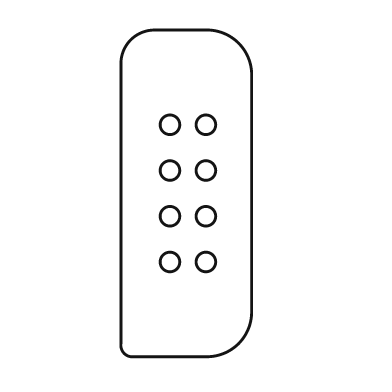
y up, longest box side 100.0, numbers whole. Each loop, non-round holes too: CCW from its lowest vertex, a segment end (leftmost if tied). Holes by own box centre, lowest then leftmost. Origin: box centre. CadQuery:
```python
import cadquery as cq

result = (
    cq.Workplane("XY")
    .moveTo(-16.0, -50.0)
    .lineTo(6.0, -50.0)
    .threePointArc((16.0, -46.0), (20.0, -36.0))
    .lineTo(20.0, 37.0)
    .threePointArc((16.0, 46.0), (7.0, 50.0))
    .lineTo(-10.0, 50.0)
    .threePointArc((-17.0, 47.0), (-20.0, 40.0))
    .lineTo(-20.0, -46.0)
    .threePointArc((-19.0, -49.0), (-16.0, -50.0))
    .close()
    .moveTo(-5.0, -21.0)
    .circle(3.0)
    .moveTo(6.0, -21.0)
    .circle(3.0)
    .moveTo(-5.0, -7.0)
    .circle(3.0)
    .moveTo(6.0, -7.0)
    .circle(3.0)
    .moveTo(-5.0, 7.0)
    .circle(3.0)
    .moveTo(6.0, 7.0)
    .circle(3.0)
    .moveTo(-5.0, 21.0)
    .circle(3.0)
    .moveTo(6.0, 21.0)
    .circle(3.0)
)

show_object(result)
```